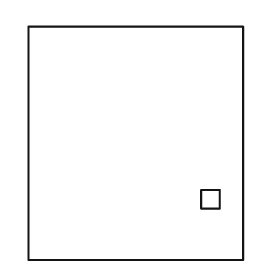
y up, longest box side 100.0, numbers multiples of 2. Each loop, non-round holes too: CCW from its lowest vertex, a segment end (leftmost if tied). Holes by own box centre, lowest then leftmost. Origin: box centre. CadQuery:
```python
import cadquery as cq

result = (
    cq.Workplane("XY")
    .moveTo(-46.0, -50.0)
    .lineTo(46.0, -50.0)
    .lineTo(46.0, 50.0)
    .lineTo(-46.0, 50.0)
    .close()
    .moveTo(28.0, -28.0)
    .lineTo(36.0, -28.0)
    .lineTo(36.0, -20.0)
    .lineTo(28.0, -20.0)
    .close()
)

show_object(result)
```